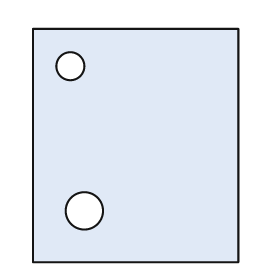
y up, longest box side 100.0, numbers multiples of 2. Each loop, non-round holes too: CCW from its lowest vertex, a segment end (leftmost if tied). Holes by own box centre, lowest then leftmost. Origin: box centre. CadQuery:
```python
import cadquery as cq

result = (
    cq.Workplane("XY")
    .moveTo(-44.0, -50.0)
    .lineTo(44.0, -50.0)
    .lineTo(44.0, 50.0)
    .lineTo(-44.0, 50.0)
    .close()
    .moveTo(-22.0, -28.0)
    .circle(8.0)
    .moveTo(-28.0, 34.0)
    .circle(6.0)
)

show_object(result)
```